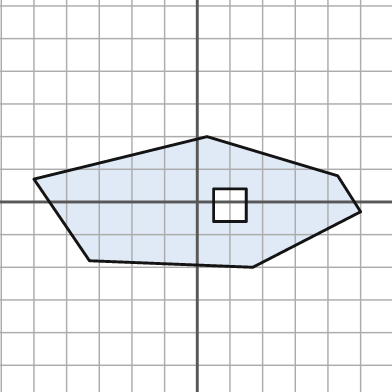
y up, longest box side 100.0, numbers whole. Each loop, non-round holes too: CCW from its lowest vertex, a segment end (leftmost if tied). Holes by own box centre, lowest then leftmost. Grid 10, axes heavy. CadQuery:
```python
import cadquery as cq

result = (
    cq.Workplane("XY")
    .moveTo(17.0, -20.0)
    .lineTo(50.0, -3.0)
    .lineTo(43.0, 8.0)
    .lineTo(3.0, 20.0)
    .lineTo(-50.0, 7.0)
    .lineTo(-33.0, -18.0)
    .close()
    .moveTo(5.0, -6.0)
    .lineTo(15.0, -6.0)
    .lineTo(15.0, 4.0)
    .lineTo(5.0, 4.0)
    .close()
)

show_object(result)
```